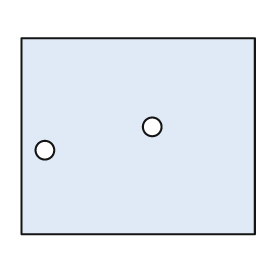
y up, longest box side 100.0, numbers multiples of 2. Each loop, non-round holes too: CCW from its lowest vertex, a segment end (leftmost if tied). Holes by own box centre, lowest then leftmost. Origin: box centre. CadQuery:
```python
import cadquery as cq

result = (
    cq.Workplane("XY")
    .moveTo(-50.0, -42.0)
    .lineTo(50.0, -42.0)
    .lineTo(50.0, 42.0)
    .lineTo(-50.0, 42.0)
    .close()
    .moveTo(-40.0, -6.0)
    .circle(4.0)
    .moveTo(6.0, 4.0)
    .circle(4.0)
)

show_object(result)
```